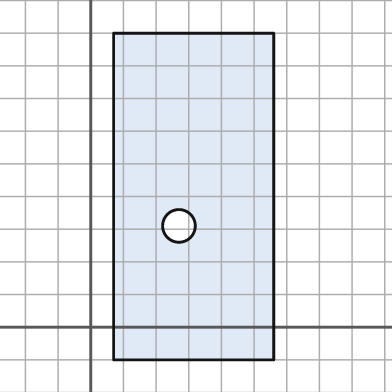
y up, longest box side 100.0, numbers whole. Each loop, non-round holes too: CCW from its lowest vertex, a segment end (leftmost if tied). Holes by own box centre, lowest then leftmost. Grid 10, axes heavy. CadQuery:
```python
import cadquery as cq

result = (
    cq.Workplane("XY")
    .moveTo(7.0, -10.0)
    .lineTo(56.0, -10.0)
    .lineTo(56.0, 90.0)
    .lineTo(7.0, 90.0)
    .close()
    .moveTo(27.0, 31.0)
    .circle(5.0)
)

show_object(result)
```